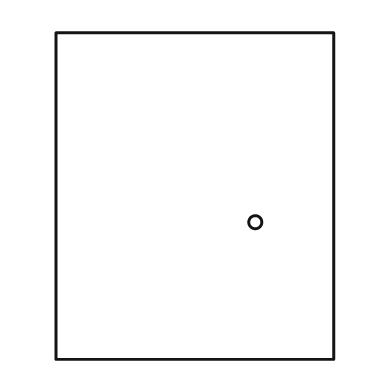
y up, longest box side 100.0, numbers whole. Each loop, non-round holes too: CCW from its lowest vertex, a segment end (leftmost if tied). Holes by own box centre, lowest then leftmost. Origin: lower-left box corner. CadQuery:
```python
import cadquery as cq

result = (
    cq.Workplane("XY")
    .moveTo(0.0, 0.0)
    .lineTo(85.0, 0.0)
    .lineTo(85.0, 100.0)
    .lineTo(0.0, 100.0)
    .close()
    .moveTo(61.0, 42.0)
    .circle(2.0)
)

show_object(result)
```